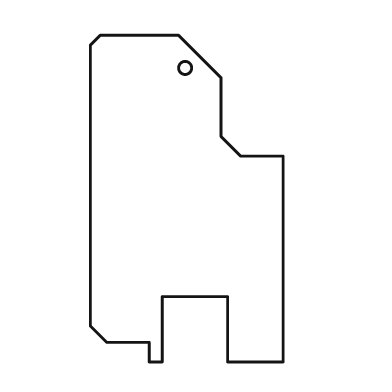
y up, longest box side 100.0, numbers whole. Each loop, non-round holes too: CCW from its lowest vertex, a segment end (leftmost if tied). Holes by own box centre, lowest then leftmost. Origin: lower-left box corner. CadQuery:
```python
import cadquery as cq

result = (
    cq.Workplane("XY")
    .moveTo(18.0, 0.0)
    .lineTo(22.0, 0.0)
    .lineTo(22.0, 20.0)
    .lineTo(42.0, 20.0)
    .lineTo(42.0, 0.0)
    .lineTo(59.0, 0.0)
    .lineTo(59.0, 63.0)
    .lineTo(46.0, 63.0)
    .lineTo(40.0, 69.0)
    .lineTo(40.0, 87.0)
    .lineTo(27.0, 100.0)
    .lineTo(3.0, 100.0)
    .lineTo(0.0, 97.0)
    .lineTo(0.0, 11.0)
    .lineTo(5.0, 6.0)
    .lineTo(18.0, 6.0)
    .close()
    .moveTo(29.0, 90.0)
    .circle(2.0)
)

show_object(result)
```